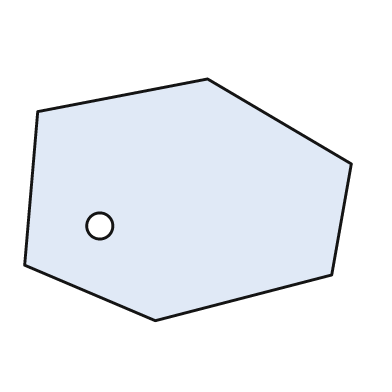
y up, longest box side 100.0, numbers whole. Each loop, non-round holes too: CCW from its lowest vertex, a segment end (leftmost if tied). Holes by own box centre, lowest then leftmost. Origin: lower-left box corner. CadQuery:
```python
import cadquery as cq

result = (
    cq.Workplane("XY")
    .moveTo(40.0, 0.0)
    .lineTo(94.0, 14.0)
    .lineTo(100.0, 48.0)
    .lineTo(56.0, 74.0)
    .lineTo(4.0, 64.0)
    .lineTo(0.0, 17.0)
    .close()
    .moveTo(23.0, 29.0)
    .circle(4.0)
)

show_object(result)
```